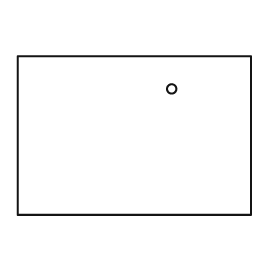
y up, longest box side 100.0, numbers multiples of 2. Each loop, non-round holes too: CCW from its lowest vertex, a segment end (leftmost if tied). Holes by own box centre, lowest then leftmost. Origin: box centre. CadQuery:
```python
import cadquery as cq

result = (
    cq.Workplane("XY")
    .moveTo(-50.0, -34.0)
    .lineTo(50.0, -34.0)
    .lineTo(50.0, 34.0)
    .lineTo(-50.0, 34.0)
    .close()
    .moveTo(16.0, 20.0)
    .circle(2.0)
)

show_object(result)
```